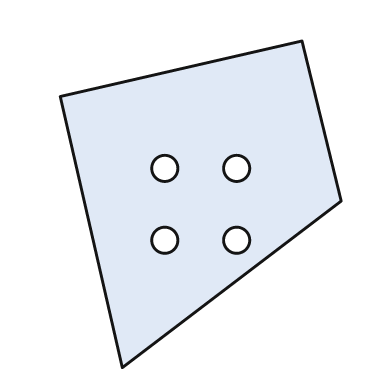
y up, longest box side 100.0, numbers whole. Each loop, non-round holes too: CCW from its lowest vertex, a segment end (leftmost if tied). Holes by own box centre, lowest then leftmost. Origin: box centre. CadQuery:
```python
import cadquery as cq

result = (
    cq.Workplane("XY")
    .moveTo(-24.0, -50.0)
    .lineTo(43.0, 1.0)
    .lineTo(31.0, 50.0)
    .lineTo(-43.0, 33.0)
    .close()
    .moveTo(-11.0, -11.0)
    .circle(4.0)
    .moveTo(11.0, -11.0)
    .circle(4.0)
    .moveTo(-11.0, 11.0)
    .circle(4.0)
    .moveTo(11.0, 11.0)
    .circle(4.0)
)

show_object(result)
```